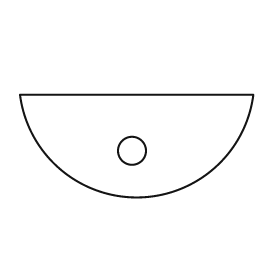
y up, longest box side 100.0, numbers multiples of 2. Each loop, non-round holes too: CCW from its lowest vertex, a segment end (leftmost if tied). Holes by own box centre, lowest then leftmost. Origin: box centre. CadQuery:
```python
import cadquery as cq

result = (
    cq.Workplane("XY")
    .moveTo(-50.0, 22.0)
    .threePointArc((0.0, -22.0), (50.0, 22.0))
    .close()
    .moveTo(-2.0, -2.0)
    .circle(6.0)
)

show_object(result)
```